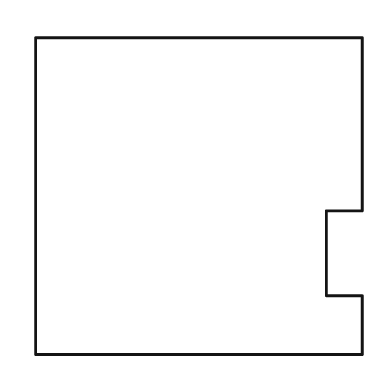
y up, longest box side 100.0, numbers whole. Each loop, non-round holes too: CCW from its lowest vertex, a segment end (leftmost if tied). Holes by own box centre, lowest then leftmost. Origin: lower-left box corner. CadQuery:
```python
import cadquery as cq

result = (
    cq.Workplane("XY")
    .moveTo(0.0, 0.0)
    .lineTo(100.0, 0.0)
    .lineTo(100.0, 18.0)
    .lineTo(89.0, 18.0)
    .lineTo(89.0, 44.0)
    .lineTo(100.0, 44.0)
    .lineTo(100.0, 97.0)
    .lineTo(0.0, 97.0)
    .close()
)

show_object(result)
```